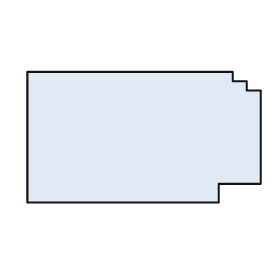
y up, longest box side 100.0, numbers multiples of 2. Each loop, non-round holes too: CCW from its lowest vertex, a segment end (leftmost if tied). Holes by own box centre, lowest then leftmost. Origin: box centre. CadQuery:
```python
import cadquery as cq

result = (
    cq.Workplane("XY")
    .moveTo(-50.0, -28.0)
    .lineTo(32.0, -28.0)
    .lineTo(32.0, -20.0)
    .lineTo(50.0, -20.0)
    .lineTo(50.0, 20.0)
    .lineTo(44.0, 20.0)
    .lineTo(44.0, 24.0)
    .lineTo(38.0, 24.0)
    .lineTo(38.0, 28.0)
    .lineTo(-50.0, 28.0)
    .close()
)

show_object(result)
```